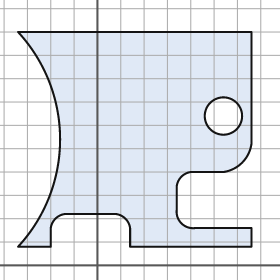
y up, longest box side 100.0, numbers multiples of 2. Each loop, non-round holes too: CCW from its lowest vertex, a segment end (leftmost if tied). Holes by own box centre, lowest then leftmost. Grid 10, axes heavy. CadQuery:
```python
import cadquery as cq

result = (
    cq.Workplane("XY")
    .moveTo(-34.0, 8.0)
    .lineTo(-20.0, 8.0)
    .lineTo(-20.0, 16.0)
    .threePointArc((-18.0, 20.0), (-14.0, 22.0))
    .lineTo(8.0, 22.0)
    .threePointArc((12.0, 20.0), (14.0, 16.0))
    .lineTo(14.0, 8.0)
    .lineTo(66.0, 8.0)
    .lineTo(66.0, 16.0)
    .lineTo(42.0, 16.0)
    .threePointArc((36.0, 18.0), (34.0, 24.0))
    .lineTo(34.0, 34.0)
    .threePointArc((36.0, 38.0), (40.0, 40.0))
    .lineTo(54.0, 40.0)
    .threePointArc((62.0, 44.0), (66.0, 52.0))
    .lineTo(66.0, 100.0)
    .lineTo(-34.0, 100.0)
    .threePointArc((-16.0, 54.0), (-34.0, 8.0))
    .close()
    .moveTo(54.0, 64.0)
    .circle(8.0)
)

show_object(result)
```